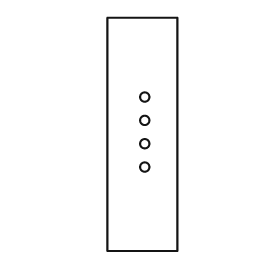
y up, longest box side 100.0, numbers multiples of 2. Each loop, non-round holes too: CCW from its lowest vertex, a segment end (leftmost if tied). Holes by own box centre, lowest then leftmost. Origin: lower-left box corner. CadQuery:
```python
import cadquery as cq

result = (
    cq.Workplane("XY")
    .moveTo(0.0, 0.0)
    .lineTo(30.0, 0.0)
    .lineTo(30.0, 100.0)
    .lineTo(0.0, 100.0)
    .close()
    .moveTo(16.0, 36.0)
    .circle(2.0)
    .moveTo(16.0, 46.0)
    .circle(2.0)
    .moveTo(16.0, 56.0)
    .circle(2.0)
    .moveTo(16.0, 66.0)
    .circle(2.0)
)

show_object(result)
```